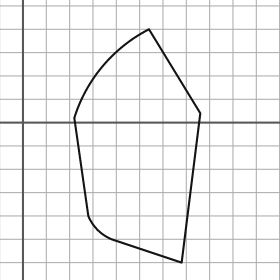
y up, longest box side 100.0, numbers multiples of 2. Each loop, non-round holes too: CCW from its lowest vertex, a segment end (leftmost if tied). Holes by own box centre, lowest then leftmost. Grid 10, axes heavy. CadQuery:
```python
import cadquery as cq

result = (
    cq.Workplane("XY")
    .moveTo(68.0, -60.0)
    .lineTo(76.0, 4.0)
    .lineTo(54.0, 40.0)
    .threePointArc((34.0, 24.0), (22.0, 2.0))
    .lineTo(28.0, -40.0)
    .threePointArc((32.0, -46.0), (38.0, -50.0))
    .close()
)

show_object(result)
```